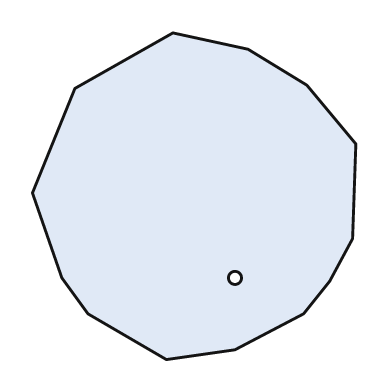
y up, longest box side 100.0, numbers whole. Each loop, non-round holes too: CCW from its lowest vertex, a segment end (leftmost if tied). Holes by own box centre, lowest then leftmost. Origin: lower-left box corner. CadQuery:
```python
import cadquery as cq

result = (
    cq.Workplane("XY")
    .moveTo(41.0, 0.0)
    .lineTo(62.0, 3.0)
    .lineTo(83.0, 14.0)
    .lineTo(91.0, 24.0)
    .lineTo(98.0, 37.0)
    .lineTo(99.0, 66.0)
    .lineTo(84.0, 84.0)
    .lineTo(66.0, 95.0)
    .lineTo(43.0, 100.0)
    .lineTo(13.0, 83.0)
    .lineTo(0.0, 51.0)
    .lineTo(9.0, 25.0)
    .lineTo(17.0, 14.0)
    .close()
    .moveTo(62.0, 25.0)
    .circle(2.0)
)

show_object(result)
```